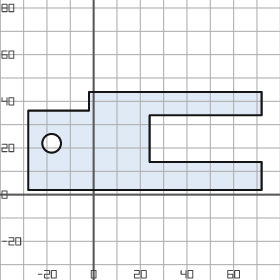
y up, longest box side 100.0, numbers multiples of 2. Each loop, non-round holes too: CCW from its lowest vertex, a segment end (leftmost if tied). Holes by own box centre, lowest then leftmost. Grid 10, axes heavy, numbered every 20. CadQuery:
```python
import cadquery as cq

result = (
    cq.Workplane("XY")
    .moveTo(-28.0, 2.0)
    .lineTo(72.0, 2.0)
    .lineTo(72.0, 14.0)
    .lineTo(24.0, 14.0)
    .lineTo(24.0, 34.0)
    .lineTo(72.0, 34.0)
    .lineTo(72.0, 44.0)
    .lineTo(-2.0, 44.0)
    .lineTo(-2.0, 36.0)
    .lineTo(-28.0, 36.0)
    .close()
    .moveTo(-18.0, 22.0)
    .circle(4.0)
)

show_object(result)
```